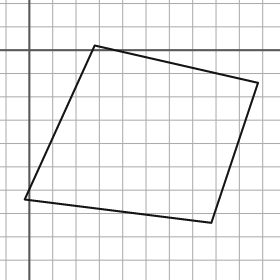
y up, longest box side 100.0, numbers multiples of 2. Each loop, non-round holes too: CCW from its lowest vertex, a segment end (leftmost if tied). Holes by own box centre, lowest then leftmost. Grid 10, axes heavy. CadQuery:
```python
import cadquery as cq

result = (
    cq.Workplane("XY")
    .moveTo(78.0, -74.0)
    .lineTo(98.0, -14.0)
    .lineTo(28.0, 2.0)
    .lineTo(-2.0, -64.0)
    .close()
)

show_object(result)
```